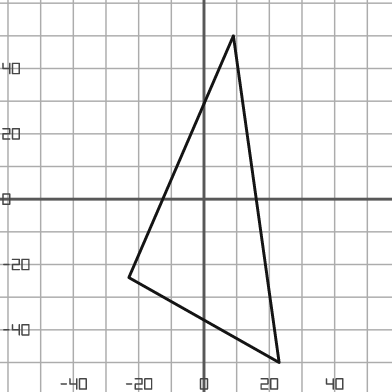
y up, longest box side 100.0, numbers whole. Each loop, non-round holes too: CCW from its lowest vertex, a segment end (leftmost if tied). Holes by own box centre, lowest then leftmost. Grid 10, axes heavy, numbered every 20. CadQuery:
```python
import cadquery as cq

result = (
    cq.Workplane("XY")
    .moveTo(23.0, -50.0)
    .lineTo(9.0, 50.0)
    .lineTo(-23.0, -24.0)
    .close()
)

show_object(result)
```